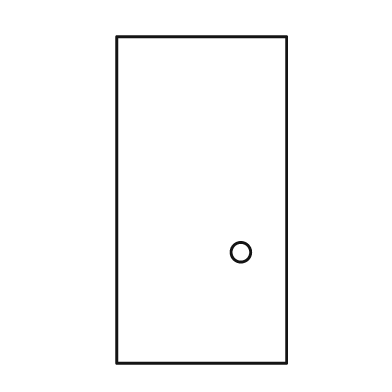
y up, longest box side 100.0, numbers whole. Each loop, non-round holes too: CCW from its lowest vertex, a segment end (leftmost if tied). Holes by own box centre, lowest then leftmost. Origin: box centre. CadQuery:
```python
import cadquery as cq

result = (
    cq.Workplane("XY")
    .moveTo(-26.0, -50.0)
    .lineTo(26.0, -50.0)
    .lineTo(26.0, 50.0)
    .lineTo(-26.0, 50.0)
    .close()
    .moveTo(12.0, -16.0)
    .circle(3.0)
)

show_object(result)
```